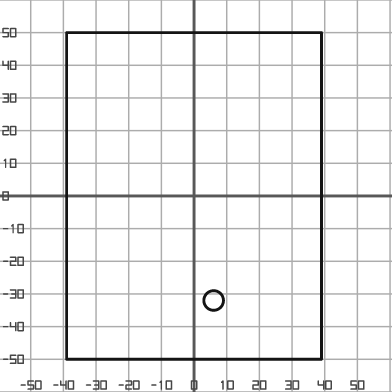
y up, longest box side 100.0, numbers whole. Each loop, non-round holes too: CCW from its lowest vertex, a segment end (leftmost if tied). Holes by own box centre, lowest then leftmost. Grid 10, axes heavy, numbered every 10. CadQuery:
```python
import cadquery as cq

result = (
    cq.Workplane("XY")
    .moveTo(-39.0, -50.0)
    .lineTo(39.0, -50.0)
    .lineTo(39.0, 50.0)
    .lineTo(-39.0, 50.0)
    .close()
    .moveTo(6.0, -32.0)
    .circle(3.0)
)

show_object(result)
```